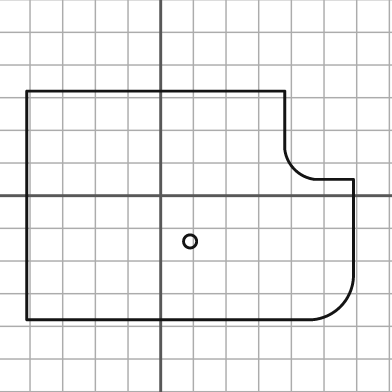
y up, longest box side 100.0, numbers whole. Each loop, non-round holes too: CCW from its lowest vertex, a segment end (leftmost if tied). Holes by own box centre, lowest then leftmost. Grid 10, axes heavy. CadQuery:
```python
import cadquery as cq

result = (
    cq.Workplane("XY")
    .moveTo(-41.0, -38.0)
    .lineTo(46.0, -38.0)
    .threePointArc((55.0, -34.0), (59.0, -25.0))
    .lineTo(59.0, 5.0)
    .lineTo(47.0, 5.0)
    .threePointArc((41.0, 8.0), (38.0, 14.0))
    .lineTo(38.0, 32.0)
    .lineTo(-41.0, 32.0)
    .close()
    .moveTo(9.0, -14.0)
    .circle(2.0)
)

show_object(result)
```